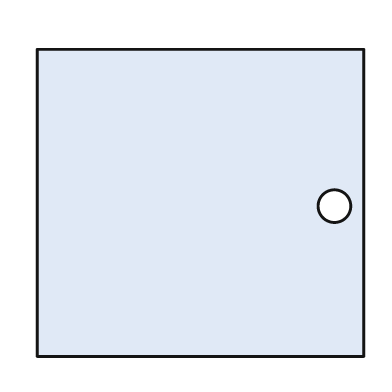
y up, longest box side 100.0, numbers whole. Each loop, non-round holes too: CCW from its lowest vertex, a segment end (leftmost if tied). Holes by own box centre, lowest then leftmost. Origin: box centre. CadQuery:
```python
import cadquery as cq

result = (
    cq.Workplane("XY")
    .moveTo(-50.0, -47.0)
    .lineTo(50.0, -47.0)
    .lineTo(50.0, 47.0)
    .lineTo(-50.0, 47.0)
    .close()
    .moveTo(41.0, -1.0)
    .circle(5.0)
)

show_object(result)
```